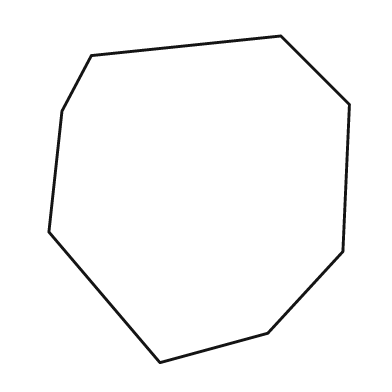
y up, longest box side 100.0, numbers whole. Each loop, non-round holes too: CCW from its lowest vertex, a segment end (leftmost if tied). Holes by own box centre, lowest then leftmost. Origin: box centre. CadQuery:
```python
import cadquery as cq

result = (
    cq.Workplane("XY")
    .moveTo(-12.0, -50.0)
    .lineTo(21.0, -41.0)
    .lineTo(44.0, -16.0)
    .lineTo(46.0, 29.0)
    .lineTo(25.0, 50.0)
    .lineTo(-33.0, 44.0)
    .lineTo(-42.0, 27.0)
    .lineTo(-46.0, -10.0)
    .close()
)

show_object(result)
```